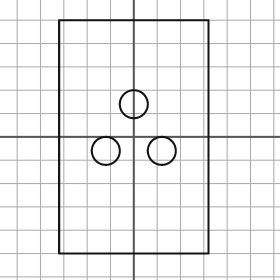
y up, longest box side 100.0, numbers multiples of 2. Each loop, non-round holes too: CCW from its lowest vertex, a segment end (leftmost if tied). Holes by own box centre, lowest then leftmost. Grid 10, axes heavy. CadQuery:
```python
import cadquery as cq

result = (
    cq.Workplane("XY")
    .moveTo(-32.0, -50.0)
    .lineTo(32.0, -50.0)
    .lineTo(32.0, 50.0)
    .lineTo(-32.0, 50.0)
    .close()
    .moveTo(-12.0, -6.0)
    .circle(6.0)
    .moveTo(12.0, -6.0)
    .circle(6.0)
    .moveTo(0.0, 14.0)
    .circle(6.0)
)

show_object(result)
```